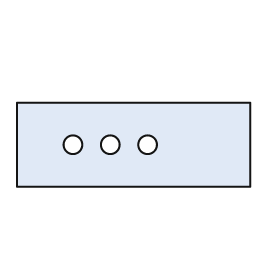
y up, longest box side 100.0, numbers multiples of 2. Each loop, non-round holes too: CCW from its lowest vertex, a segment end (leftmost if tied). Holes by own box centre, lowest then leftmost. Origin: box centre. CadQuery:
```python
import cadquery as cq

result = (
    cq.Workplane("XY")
    .moveTo(-50.0, -18.0)
    .lineTo(50.0, -18.0)
    .lineTo(50.0, 18.0)
    .lineTo(-50.0, 18.0)
    .close()
    .moveTo(-26.0, 0.0)
    .circle(4.0)
    .moveTo(-10.0, 0.0)
    .circle(4.0)
    .moveTo(6.0, 0.0)
    .circle(4.0)
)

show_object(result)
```